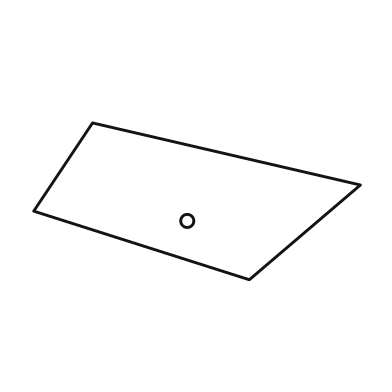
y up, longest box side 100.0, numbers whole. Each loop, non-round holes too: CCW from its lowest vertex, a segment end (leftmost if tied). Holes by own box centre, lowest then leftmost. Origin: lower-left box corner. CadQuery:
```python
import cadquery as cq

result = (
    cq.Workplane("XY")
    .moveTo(66.0, 0.0)
    .lineTo(100.0, 29.0)
    .lineTo(18.0, 48.0)
    .lineTo(0.0, 21.0)
    .close()
    .moveTo(47.0, 18.0)
    .circle(2.0)
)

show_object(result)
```